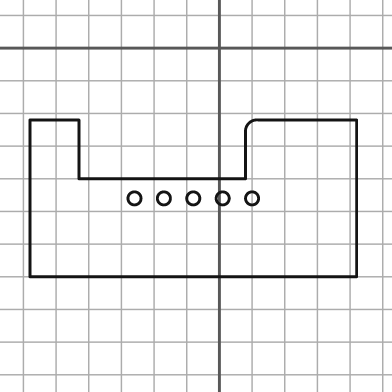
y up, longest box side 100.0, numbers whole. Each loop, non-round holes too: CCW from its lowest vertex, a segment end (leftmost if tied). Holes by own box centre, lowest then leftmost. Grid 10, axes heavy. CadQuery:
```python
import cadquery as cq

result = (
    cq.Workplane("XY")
    .moveTo(-58.0, -70.0)
    .lineTo(42.0, -70.0)
    .lineTo(42.0, -22.0)
    .lineTo(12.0, -22.0)
    .threePointArc((9.0, -23.0), (8.0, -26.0))
    .lineTo(8.0, -40.0)
    .lineTo(-43.0, -40.0)
    .lineTo(-43.0, -22.0)
    .lineTo(-58.0, -22.0)
    .close()
    .moveTo(-26.0, -46.0)
    .circle(2.0)
    .moveTo(-17.0, -46.0)
    .circle(2.0)
    .moveTo(-8.0, -46.0)
    .circle(2.0)
    .moveTo(1.0, -46.0)
    .circle(2.0)
    .moveTo(10.0, -46.0)
    .circle(2.0)
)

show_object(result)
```